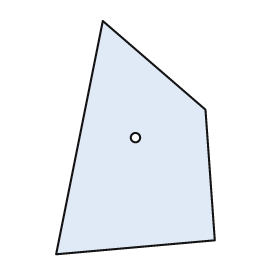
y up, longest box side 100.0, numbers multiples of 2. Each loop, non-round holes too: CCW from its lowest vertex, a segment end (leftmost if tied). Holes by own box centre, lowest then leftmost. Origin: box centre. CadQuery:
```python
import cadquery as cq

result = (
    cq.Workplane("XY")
    .moveTo(-34.0, -50.0)
    .lineTo(34.0, -44.0)
    .lineTo(30.0, 12.0)
    .lineTo(-14.0, 50.0)
    .close()
    .moveTo(0.0, 0.0)
    .circle(2.0)
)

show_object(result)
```